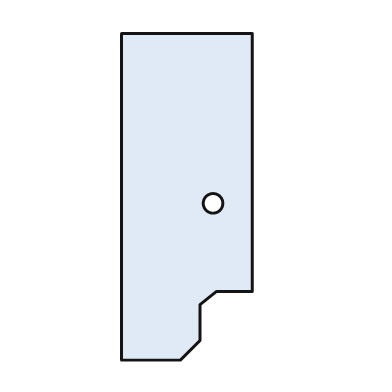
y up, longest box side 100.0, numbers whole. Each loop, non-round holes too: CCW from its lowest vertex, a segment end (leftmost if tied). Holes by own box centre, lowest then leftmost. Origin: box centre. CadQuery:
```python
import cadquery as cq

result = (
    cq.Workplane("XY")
    .moveTo(-20.0, -50.0)
    .lineTo(-2.0, -50.0)
    .lineTo(4.0, -44.0)
    .lineTo(4.0, -33.0)
    .lineTo(9.0, -29.0)
    .lineTo(20.0, -29.0)
    .lineTo(20.0, 50.0)
    .lineTo(-20.0, 50.0)
    .close()
    .moveTo(8.0, -2.0)
    .circle(3.0)
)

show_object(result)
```